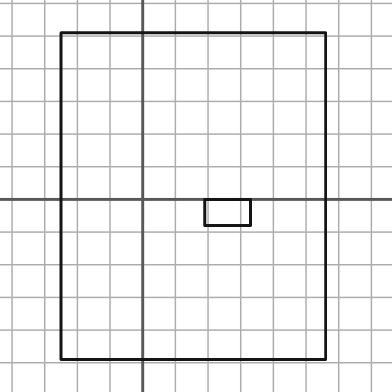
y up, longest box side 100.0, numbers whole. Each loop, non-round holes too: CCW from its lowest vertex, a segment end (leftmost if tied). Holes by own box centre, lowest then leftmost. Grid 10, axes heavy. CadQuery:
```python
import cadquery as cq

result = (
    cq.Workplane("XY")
    .moveTo(-25.0, -49.0)
    .lineTo(56.0, -49.0)
    .lineTo(56.0, 51.0)
    .lineTo(-25.0, 51.0)
    .close()
    .moveTo(19.0, -8.0)
    .lineTo(33.0, -8.0)
    .lineTo(33.0, 0.0)
    .lineTo(19.0, 0.0)
    .close()
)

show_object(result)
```